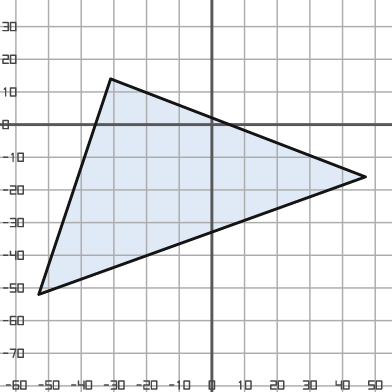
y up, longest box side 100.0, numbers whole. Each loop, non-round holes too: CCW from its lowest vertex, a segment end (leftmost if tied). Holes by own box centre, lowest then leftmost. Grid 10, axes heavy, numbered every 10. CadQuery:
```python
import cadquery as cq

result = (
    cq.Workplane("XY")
    .moveTo(-53.0, -52.0)
    .lineTo(47.0, -16.0)
    .lineTo(-31.0, 14.0)
    .close()
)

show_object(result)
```